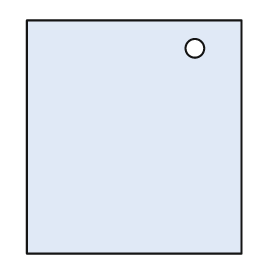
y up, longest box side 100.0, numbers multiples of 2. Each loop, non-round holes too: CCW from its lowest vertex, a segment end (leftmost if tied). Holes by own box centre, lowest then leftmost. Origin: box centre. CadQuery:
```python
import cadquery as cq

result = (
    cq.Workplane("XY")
    .moveTo(-46.0, -50.0)
    .lineTo(46.0, -50.0)
    .lineTo(46.0, 50.0)
    .lineTo(-46.0, 50.0)
    .close()
    .moveTo(26.0, 38.0)
    .circle(4.0)
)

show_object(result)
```